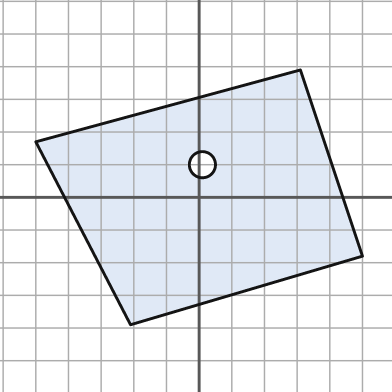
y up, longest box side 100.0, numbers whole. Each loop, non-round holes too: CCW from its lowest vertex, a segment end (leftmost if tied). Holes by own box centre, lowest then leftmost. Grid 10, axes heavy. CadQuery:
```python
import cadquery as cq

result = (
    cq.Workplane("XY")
    .moveTo(-21.0, -39.0)
    .lineTo(50.0, -18.0)
    .lineTo(31.0, 39.0)
    .lineTo(-50.0, 17.0)
    .close()
    .moveTo(1.0, 10.0)
    .circle(4.0)
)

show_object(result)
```